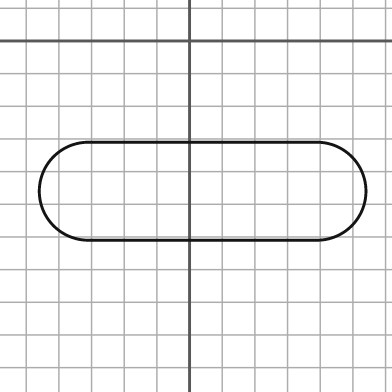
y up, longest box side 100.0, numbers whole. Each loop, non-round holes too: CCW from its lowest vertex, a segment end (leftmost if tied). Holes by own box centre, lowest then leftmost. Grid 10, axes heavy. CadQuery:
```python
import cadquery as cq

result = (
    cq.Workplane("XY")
    .moveTo(-31.0, -61.0)
    .lineTo(39.0, -61.0)
    .threePointArc((54.0, -46.0), (39.0, -31.0))
    .lineTo(-31.0, -31.0)
    .threePointArc((-46.0, -46.0), (-31.0, -61.0))
    .close()
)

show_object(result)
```